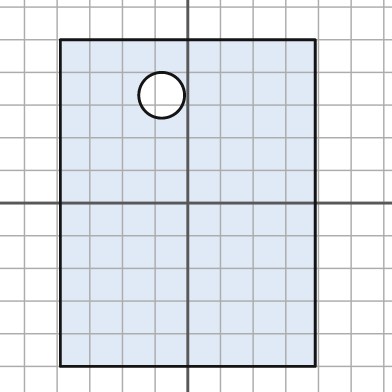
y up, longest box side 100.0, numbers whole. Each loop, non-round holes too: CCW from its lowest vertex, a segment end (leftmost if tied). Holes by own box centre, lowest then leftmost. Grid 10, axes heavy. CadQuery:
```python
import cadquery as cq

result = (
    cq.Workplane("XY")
    .moveTo(-39.0, -50.0)
    .lineTo(39.0, -50.0)
    .lineTo(39.0, 50.0)
    .lineTo(-39.0, 50.0)
    .close()
    .moveTo(-8.0, 33.0)
    .circle(7.0)
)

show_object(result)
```